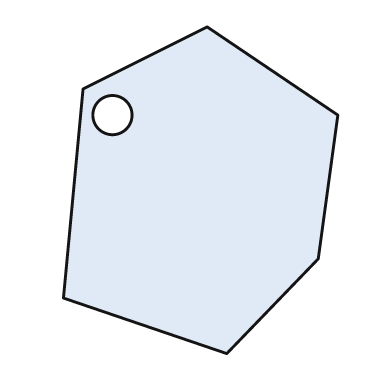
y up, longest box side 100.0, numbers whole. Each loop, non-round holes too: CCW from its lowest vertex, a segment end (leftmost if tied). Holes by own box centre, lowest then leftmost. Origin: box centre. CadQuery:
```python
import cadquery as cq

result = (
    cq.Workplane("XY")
    .moveTo(8.0, -50.0)
    .lineTo(36.0, -21.0)
    .lineTo(42.0, 23.0)
    .lineTo(2.0, 50.0)
    .lineTo(-36.0, 31.0)
    .lineTo(-42.0, -33.0)
    .close()
    .moveTo(-27.0, 23.0)
    .circle(6.0)
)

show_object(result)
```